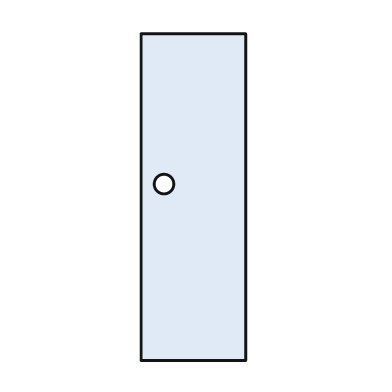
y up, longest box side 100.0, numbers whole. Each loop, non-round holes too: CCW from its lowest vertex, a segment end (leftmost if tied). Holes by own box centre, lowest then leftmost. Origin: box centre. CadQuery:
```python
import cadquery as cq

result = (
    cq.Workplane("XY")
    .moveTo(-16.0, -50.0)
    .lineTo(16.0, -50.0)
    .lineTo(16.0, 50.0)
    .lineTo(-16.0, 50.0)
    .close()
    .moveTo(-9.0, 4.0)
    .circle(3.0)
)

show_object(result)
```